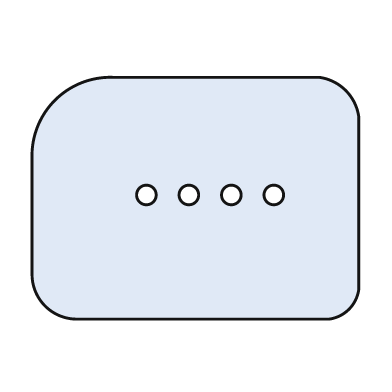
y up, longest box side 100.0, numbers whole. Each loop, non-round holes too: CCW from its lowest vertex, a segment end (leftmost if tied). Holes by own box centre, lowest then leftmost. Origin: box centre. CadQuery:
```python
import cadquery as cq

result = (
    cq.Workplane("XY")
    .moveTo(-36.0, -37.0)
    .lineTo(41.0, -37.0)
    .threePointArc((47.0, -34.0), (50.0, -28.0))
    .lineTo(50.0, 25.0)
    .threePointArc((46.0, 33.0), (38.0, 37.0))
    .lineTo(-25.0, 37.0)
    .threePointArc((-43.0, 30.0), (-50.0, 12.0))
    .lineTo(-50.0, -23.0)
    .threePointArc((-46.0, -33.0), (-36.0, -37.0))
    .close()
    .moveTo(-15.0, 1.0)
    .circle(3.0)
    .moveTo(-2.0, 1.0)
    .circle(3.0)
    .moveTo(11.0, 1.0)
    .circle(3.0)
    .moveTo(24.0, 1.0)
    .circle(3.0)
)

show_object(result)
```